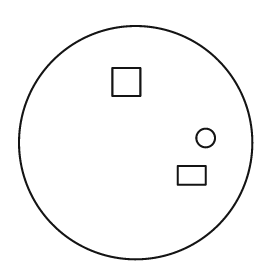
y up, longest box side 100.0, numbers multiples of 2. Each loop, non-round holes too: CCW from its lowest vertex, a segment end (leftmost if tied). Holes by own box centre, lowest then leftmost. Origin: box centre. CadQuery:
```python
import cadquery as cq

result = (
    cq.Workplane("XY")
    .moveTo(0.0, 0.0)
    .circle(50.0)
    .moveTo(18.0, -18.0)
    .lineTo(30.0, -18.0)
    .lineTo(30.0, -10.0)
    .lineTo(18.0, -10.0)
    .close()
    .moveTo(30.0, 2.0)
    .circle(4.0)
    .moveTo(-10.0, 20.0)
    .lineTo(2.0, 20.0)
    .lineTo(2.0, 32.0)
    .lineTo(-10.0, 32.0)
    .close()
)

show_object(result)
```